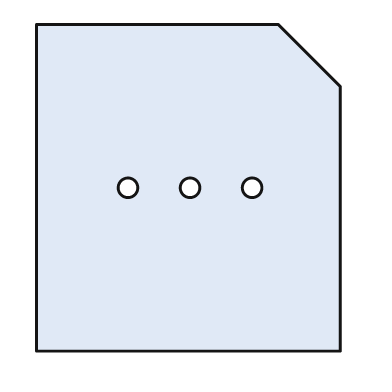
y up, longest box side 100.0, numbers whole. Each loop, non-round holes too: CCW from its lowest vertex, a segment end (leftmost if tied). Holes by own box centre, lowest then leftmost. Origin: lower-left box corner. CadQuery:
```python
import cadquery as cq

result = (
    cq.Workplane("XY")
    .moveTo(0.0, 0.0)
    .lineTo(93.0, 0.0)
    .lineTo(93.0, 81.0)
    .lineTo(74.0, 100.0)
    .lineTo(0.0, 100.0)
    .close()
    .moveTo(28.0, 50.0)
    .circle(3.0)
    .moveTo(47.0, 50.0)
    .circle(3.0)
    .moveTo(66.0, 50.0)
    .circle(3.0)
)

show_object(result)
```